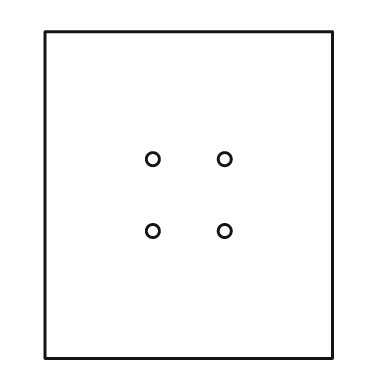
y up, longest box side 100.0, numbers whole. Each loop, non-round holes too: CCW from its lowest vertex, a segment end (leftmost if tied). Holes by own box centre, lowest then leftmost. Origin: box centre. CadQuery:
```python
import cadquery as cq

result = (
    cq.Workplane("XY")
    .moveTo(-44.0, -50.0)
    .lineTo(44.0, -50.0)
    .lineTo(44.0, 50.0)
    .lineTo(-44.0, 50.0)
    .close()
    .moveTo(-11.0, -11.0)
    .circle(2.0)
    .moveTo(11.0, -11.0)
    .circle(2.0)
    .moveTo(-11.0, 11.0)
    .circle(2.0)
    .moveTo(11.0, 11.0)
    .circle(2.0)
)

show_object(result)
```